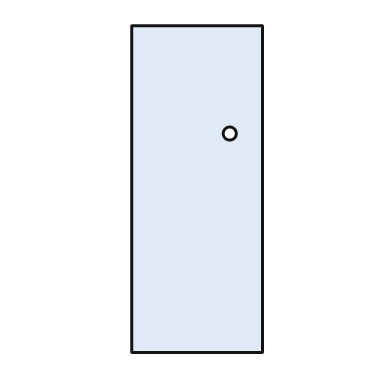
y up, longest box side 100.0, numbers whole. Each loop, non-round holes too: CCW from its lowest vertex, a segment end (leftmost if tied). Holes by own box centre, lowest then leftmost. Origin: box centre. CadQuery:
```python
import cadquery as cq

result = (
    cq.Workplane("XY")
    .moveTo(-20.0, -50.0)
    .lineTo(20.0, -50.0)
    .lineTo(20.0, 50.0)
    .lineTo(-20.0, 50.0)
    .close()
    .moveTo(10.0, 17.0)
    .circle(2.0)
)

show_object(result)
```